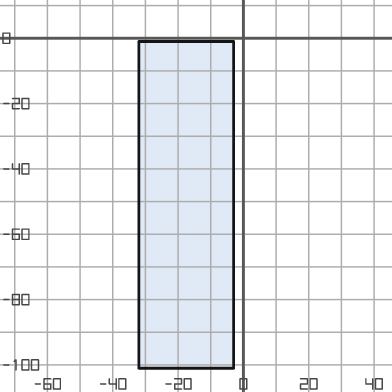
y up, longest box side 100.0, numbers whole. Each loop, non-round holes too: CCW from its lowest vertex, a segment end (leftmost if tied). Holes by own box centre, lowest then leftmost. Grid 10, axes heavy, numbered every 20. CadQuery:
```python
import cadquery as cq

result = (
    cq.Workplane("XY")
    .moveTo(-32.0, -101.0)
    .lineTo(-3.0, -101.0)
    .lineTo(-3.0, -1.0)
    .lineTo(-32.0, -1.0)
    .close()
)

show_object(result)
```